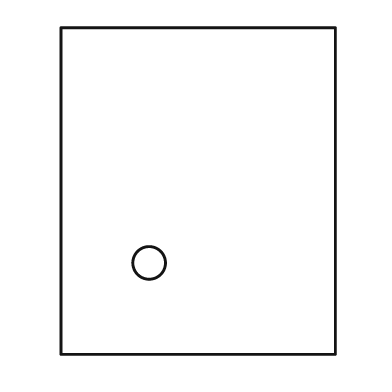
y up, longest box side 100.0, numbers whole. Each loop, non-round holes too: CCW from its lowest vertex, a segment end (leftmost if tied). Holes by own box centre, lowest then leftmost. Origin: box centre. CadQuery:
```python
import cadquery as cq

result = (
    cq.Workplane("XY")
    .moveTo(-42.0, -50.0)
    .lineTo(42.0, -50.0)
    .lineTo(42.0, 50.0)
    .lineTo(-42.0, 50.0)
    .close()
    .moveTo(-15.0, -22.0)
    .circle(5.0)
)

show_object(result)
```